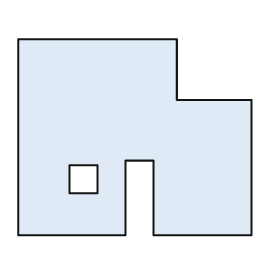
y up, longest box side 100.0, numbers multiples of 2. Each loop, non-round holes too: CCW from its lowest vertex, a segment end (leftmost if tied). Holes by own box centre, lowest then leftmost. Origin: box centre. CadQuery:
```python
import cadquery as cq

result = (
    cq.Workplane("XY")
    .moveTo(-50.0, -42.0)
    .lineTo(-4.0, -42.0)
    .lineTo(-4.0, -10.0)
    .lineTo(8.0, -10.0)
    .lineTo(8.0, -42.0)
    .lineTo(50.0, -42.0)
    .lineTo(50.0, 16.0)
    .lineTo(18.0, 16.0)
    .lineTo(18.0, 42.0)
    .lineTo(-50.0, 42.0)
    .close()
    .moveTo(-28.0, -24.0)
    .lineTo(-16.0, -24.0)
    .lineTo(-16.0, -12.0)
    .lineTo(-28.0, -12.0)
    .close()
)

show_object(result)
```